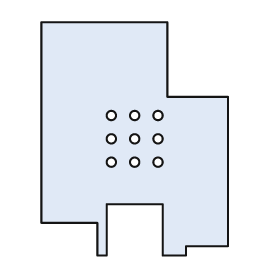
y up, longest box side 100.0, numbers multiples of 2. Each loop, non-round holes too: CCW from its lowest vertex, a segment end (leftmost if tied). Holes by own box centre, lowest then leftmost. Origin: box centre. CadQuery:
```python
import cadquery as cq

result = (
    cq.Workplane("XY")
    .moveTo(-16.0, -50.0)
    .lineTo(-12.0, -50.0)
    .lineTo(-12.0, -28.0)
    .lineTo(12.0, -28.0)
    .lineTo(12.0, -50.0)
    .lineTo(22.0, -50.0)
    .lineTo(22.0, -46.0)
    .lineTo(40.0, -46.0)
    .lineTo(40.0, 18.0)
    .lineTo(14.0, 18.0)
    .lineTo(14.0, 50.0)
    .lineTo(-40.0, 50.0)
    .lineTo(-40.0, -36.0)
    .lineTo(-16.0, -36.0)
    .close()
    .moveTo(-10.0, -10.0)
    .circle(2.0)
    .moveTo(0.0, -10.0)
    .circle(2.0)
    .moveTo(10.0, -10.0)
    .circle(2.0)
    .moveTo(-10.0, 0.0)
    .circle(2.0)
    .moveTo(0.0, 0.0)
    .circle(2.0)
    .moveTo(10.0, 0.0)
    .circle(2.0)
    .moveTo(-10.0, 10.0)
    .circle(2.0)
    .moveTo(0.0, 10.0)
    .circle(2.0)
    .moveTo(10.0, 10.0)
    .circle(2.0)
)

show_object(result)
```